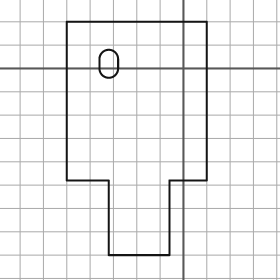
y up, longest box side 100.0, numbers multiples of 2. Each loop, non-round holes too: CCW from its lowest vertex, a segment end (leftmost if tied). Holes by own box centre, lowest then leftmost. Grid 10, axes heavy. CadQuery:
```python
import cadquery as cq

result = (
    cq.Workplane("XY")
    .moveTo(-32.0, -80.0)
    .lineTo(-6.0, -80.0)
    .lineTo(-6.0, -48.0)
    .lineTo(10.0, -48.0)
    .lineTo(10.0, 20.0)
    .lineTo(-50.0, 20.0)
    .lineTo(-50.0, -48.0)
    .lineTo(-32.0, -48.0)
    .close()
    .moveTo(-36.0, 0.0)
    .threePointArc((-32.0, -4.0), (-28.0, 0.0))
    .lineTo(-28.0, 4.0)
    .threePointArc((-32.0, 8.0), (-36.0, 4.0))
    .close()
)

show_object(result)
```